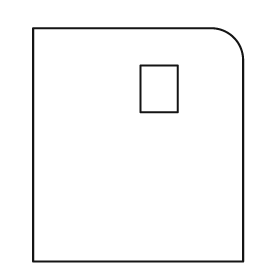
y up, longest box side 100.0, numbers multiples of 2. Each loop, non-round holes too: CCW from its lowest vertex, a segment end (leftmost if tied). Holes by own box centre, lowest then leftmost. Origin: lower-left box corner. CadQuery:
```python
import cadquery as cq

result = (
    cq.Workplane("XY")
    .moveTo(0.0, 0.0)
    .lineTo(90.0, 0.0)
    .lineTo(90.0, 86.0)
    .threePointArc((86.0, 96.0), (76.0, 100.0))
    .lineTo(0.0, 100.0)
    .close()
    .moveTo(46.0, 64.0)
    .lineTo(62.0, 64.0)
    .lineTo(62.0, 84.0)
    .lineTo(46.0, 84.0)
    .close()
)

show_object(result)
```